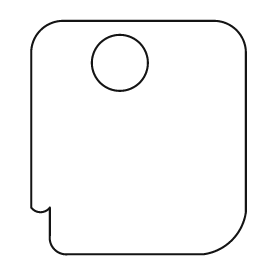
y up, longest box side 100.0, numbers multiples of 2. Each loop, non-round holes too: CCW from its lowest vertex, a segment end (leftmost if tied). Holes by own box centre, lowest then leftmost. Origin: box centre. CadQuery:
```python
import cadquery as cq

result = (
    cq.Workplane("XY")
    .moveTo(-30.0, -50.0)
    .lineTo(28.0, -50.0)
    .threePointArc((40.0, -44.0), (46.0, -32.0))
    .lineTo(46.0, 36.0)
    .threePointArc((42.0, 46.0), (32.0, 50.0))
    .lineTo(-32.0, 50.0)
    .threePointArc((-42.0, 46.0), (-46.0, 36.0))
    .lineTo(-46.0, -30.0)
    .threePointArc((-42.0, -32.0), (-38.0, -30.0))
    .lineTo(-38.0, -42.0)
    .threePointArc((-36.0, -48.0), (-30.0, -50.0))
    .close()
    .moveTo(-8.0, 32.0)
    .circle(12.0)
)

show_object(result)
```